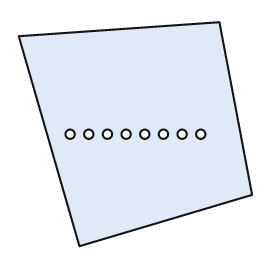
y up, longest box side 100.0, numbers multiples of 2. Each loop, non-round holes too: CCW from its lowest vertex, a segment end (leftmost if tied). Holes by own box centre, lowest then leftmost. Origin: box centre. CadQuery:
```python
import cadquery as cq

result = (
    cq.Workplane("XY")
    .moveTo(-24.0, -48.0)
    .lineTo(50.0, -26.0)
    .lineTo(36.0, 48.0)
    .lineTo(-50.0, 42.0)
    .close()
    .moveTo(-28.0, 0.0)
    .circle(2.0)
    .moveTo(-20.0, 0.0)
    .circle(2.0)
    .moveTo(-12.0, 0.0)
    .circle(2.0)
    .moveTo(-4.0, 0.0)
    .circle(2.0)
    .moveTo(4.0, 0.0)
    .circle(2.0)
    .moveTo(12.0, 0.0)
    .circle(2.0)
    .moveTo(20.0, 0.0)
    .circle(2.0)
    .moveTo(28.0, 0.0)
    .circle(2.0)
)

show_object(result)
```